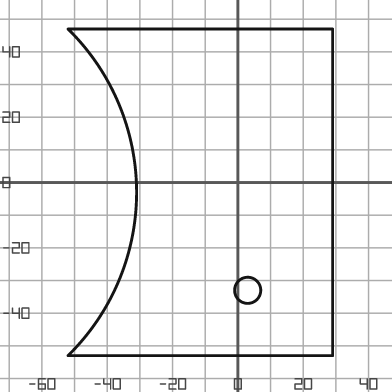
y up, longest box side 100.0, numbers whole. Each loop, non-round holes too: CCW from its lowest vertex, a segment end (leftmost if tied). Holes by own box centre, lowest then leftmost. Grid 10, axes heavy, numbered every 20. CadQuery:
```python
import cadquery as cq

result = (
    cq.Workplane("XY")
    .moveTo(-52.0, -53.0)
    .lineTo(29.0, -53.0)
    .lineTo(29.0, 47.0)
    .lineTo(-52.0, 47.0)
    .threePointArc((-31.0, -3.0), (-52.0, -53.0))
    .close()
    .moveTo(3.0, -33.0)
    .circle(4.0)
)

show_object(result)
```